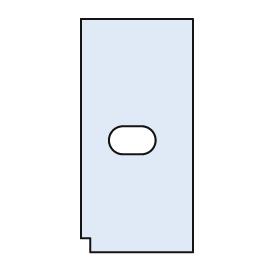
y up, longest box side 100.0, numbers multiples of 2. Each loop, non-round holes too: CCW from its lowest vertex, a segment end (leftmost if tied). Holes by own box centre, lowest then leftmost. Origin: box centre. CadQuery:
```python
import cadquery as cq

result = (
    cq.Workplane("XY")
    .moveTo(-20.0, -50.0)
    .lineTo(24.0, -50.0)
    .lineTo(24.0, 50.0)
    .lineTo(-24.0, 50.0)
    .lineTo(-24.0, -44.0)
    .lineTo(-20.0, -44.0)
    .close()
    .moveTo(-6.0, -8.0)
    .lineTo(2.0, -8.0)
    .threePointArc((8.0, -2.0), (2.0, 4.0))
    .lineTo(-6.0, 4.0)
    .threePointArc((-12.0, -2.0), (-6.0, -8.0))
    .close()
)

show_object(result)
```